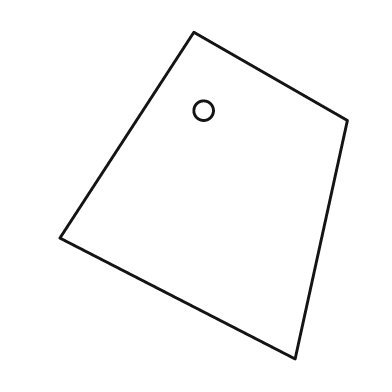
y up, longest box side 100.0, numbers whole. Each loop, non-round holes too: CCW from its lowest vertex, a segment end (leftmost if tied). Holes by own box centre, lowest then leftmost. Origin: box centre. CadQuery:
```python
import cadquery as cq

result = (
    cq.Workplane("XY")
    .moveTo(28.0, -50.0)
    .lineTo(44.0, 23.0)
    .lineTo(-3.0, 50.0)
    .lineTo(-44.0, -13.0)
    .close()
    .moveTo(0.0, 26.0)
    .circle(3.0)
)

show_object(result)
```